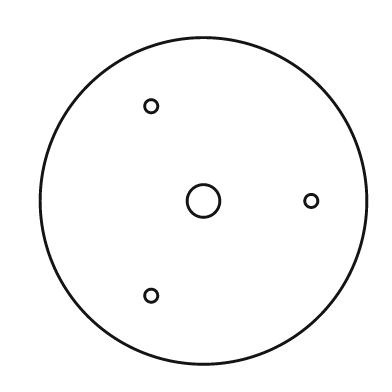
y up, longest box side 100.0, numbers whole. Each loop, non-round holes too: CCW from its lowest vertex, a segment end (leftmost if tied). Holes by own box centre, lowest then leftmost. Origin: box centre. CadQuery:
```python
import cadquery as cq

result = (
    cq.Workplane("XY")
    .moveTo(0.0, 0.0)
    .circle(50.0)
    .moveTo(-16.0, -29.0)
    .circle(2.0)
    .moveTo(0.0, 0.0)
    .circle(5.0)
    .moveTo(33.0, 0.0)
    .circle(2.0)
    .moveTo(-16.0, 29.0)
    .circle(2.0)
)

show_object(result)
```